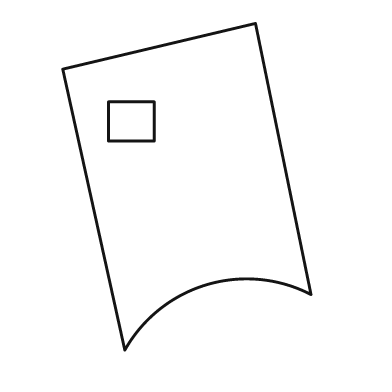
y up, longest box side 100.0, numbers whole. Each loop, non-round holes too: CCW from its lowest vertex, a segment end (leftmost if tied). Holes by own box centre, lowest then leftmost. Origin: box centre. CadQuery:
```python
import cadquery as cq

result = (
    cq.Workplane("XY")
    .moveTo(-19.0, -50.0)
    .threePointArc((6.0, -30.0), (38.0, -33.0))
    .lineTo(21.0, 50.0)
    .lineTo(-38.0, 36.0)
    .close()
    .moveTo(-24.0, 14.0)
    .lineTo(-10.0, 14.0)
    .lineTo(-10.0, 26.0)
    .lineTo(-24.0, 26.0)
    .close()
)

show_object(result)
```